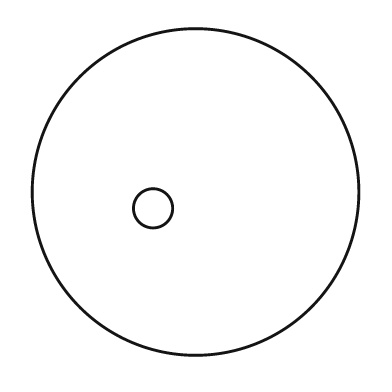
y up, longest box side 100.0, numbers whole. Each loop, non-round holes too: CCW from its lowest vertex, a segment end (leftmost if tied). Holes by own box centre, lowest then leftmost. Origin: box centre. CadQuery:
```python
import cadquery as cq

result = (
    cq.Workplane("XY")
    .moveTo(0.0, 0.0)
    .circle(50.0)
    .moveTo(-13.0, -5.0)
    .circle(6.0)
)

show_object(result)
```